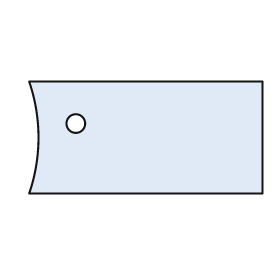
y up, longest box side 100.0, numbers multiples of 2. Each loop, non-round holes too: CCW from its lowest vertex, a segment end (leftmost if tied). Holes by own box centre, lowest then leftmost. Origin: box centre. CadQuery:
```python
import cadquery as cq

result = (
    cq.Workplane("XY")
    .moveTo(-50.0, -24.0)
    .lineTo(50.0, -24.0)
    .lineTo(50.0, 24.0)
    .lineTo(-50.0, 24.0)
    .threePointArc((-46.0, 0.0), (-50.0, -24.0))
    .close()
    .moveTo(-30.0, 6.0)
    .circle(4.0)
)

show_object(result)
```